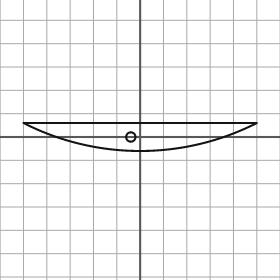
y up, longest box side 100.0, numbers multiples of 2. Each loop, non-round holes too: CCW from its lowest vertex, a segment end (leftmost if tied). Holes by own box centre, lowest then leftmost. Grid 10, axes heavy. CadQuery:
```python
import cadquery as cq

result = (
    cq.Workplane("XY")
    .moveTo(-50.0, 6.0)
    .threePointArc((0.0, -6.0), (50.0, 6.0))
    .close()
    .moveTo(-4.0, 0.0)
    .circle(2.0)
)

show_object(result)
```